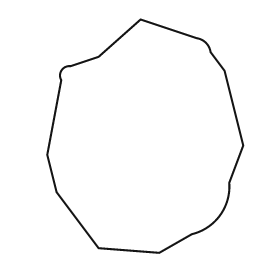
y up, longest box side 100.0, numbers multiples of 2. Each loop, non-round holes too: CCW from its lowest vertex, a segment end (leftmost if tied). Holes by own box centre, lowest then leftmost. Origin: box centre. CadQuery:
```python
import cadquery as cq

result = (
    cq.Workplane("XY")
    .moveTo(6.0, -50.0)
    .lineTo(20.0, -42.0)
    .threePointArc((32.0, -34.0), (36.0, -20.0))
    .lineTo(42.0, -4.0)
    .lineTo(34.0, 28.0)
    .lineTo(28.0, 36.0)
    .threePointArc((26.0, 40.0), (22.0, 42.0))
    .lineTo(-2.0, 50.0)
    .lineTo(-20.0, 34.0)
    .lineTo(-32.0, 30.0)
    .threePointArc((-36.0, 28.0), (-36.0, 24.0))
    .lineTo(-42.0, -8.0)
    .lineTo(-38.0, -24.0)
    .lineTo(-20.0, -48.0)
    .close()
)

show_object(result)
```